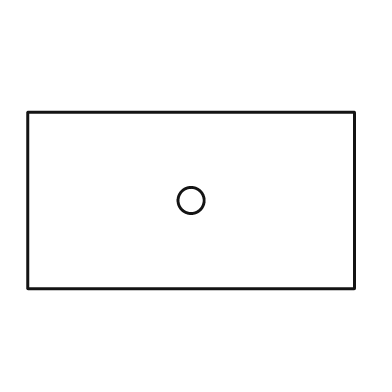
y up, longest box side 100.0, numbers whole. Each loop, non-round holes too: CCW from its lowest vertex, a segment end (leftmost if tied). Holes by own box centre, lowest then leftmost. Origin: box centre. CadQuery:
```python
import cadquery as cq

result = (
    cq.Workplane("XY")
    .moveTo(-50.0, -27.0)
    .lineTo(50.0, -27.0)
    .lineTo(50.0, 27.0)
    .lineTo(-50.0, 27.0)
    .close()
    .moveTo(0.0, 0.0)
    .circle(4.0)
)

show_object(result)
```